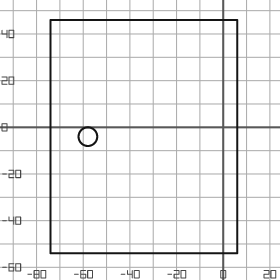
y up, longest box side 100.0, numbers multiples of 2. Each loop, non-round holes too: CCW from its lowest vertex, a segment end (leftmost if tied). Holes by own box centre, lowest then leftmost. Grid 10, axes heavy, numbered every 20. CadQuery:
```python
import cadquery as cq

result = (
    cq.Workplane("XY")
    .moveTo(-74.0, -54.0)
    .lineTo(6.0, -54.0)
    .lineTo(6.0, 46.0)
    .lineTo(-74.0, 46.0)
    .close()
    .moveTo(-58.0, -4.0)
    .circle(4.0)
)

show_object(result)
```